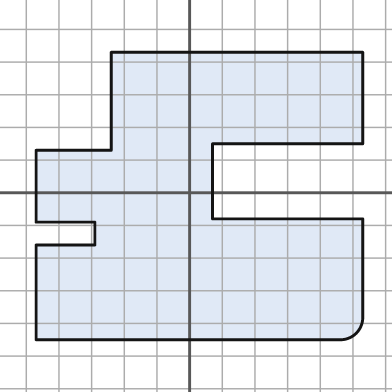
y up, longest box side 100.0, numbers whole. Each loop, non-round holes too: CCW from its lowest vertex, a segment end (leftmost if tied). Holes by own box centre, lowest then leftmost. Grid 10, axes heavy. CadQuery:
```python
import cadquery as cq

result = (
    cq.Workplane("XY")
    .moveTo(-47.0, -45.0)
    .lineTo(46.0, -45.0)
    .threePointArc((51.0, -43.0), (53.0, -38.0))
    .lineTo(53.0, -8.0)
    .lineTo(7.0, -8.0)
    .lineTo(7.0, 15.0)
    .lineTo(53.0, 15.0)
    .lineTo(53.0, 43.0)
    .lineTo(-24.0, 43.0)
    .lineTo(-24.0, 13.0)
    .lineTo(-47.0, 13.0)
    .lineTo(-47.0, -9.0)
    .lineTo(-29.0, -9.0)
    .lineTo(-29.0, -16.0)
    .lineTo(-47.0, -16.0)
    .close()
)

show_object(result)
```